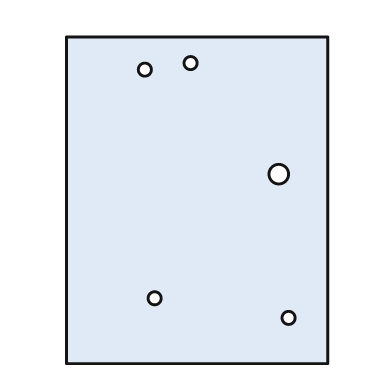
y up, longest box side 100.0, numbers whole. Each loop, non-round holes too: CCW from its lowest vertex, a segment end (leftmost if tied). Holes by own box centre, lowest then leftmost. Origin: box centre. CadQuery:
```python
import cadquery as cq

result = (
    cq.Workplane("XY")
    .moveTo(-40.0, -50.0)
    .lineTo(40.0, -50.0)
    .lineTo(40.0, 50.0)
    .lineTo(-40.0, 50.0)
    .close()
    .moveTo(28.0, -36.0)
    .circle(2.0)
    .moveTo(-13.0, -30.0)
    .circle(2.0)
    .moveTo(25.0, 8.0)
    .circle(3.0)
    .moveTo(-16.0, 40.0)
    .circle(2.0)
    .moveTo(-2.0, 42.0)
    .circle(2.0)
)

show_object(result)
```